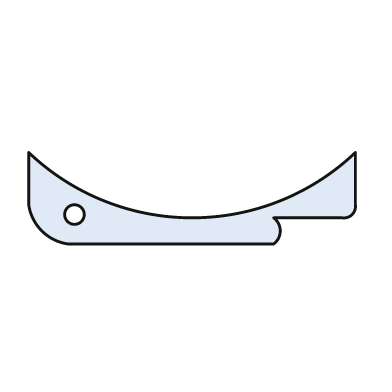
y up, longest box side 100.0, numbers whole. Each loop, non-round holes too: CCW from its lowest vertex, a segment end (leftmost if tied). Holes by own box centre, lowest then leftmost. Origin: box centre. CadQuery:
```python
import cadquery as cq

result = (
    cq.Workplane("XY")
    .moveTo(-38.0, -14.0)
    .lineTo(25.0, -14.0)
    .threePointArc((27.0, -10.0), (25.0, -6.0))
    .lineTo(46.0, -6.0)
    .threePointArc((49.0, -5.0), (50.0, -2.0))
    .lineTo(50.0, 14.0)
    .threePointArc((0.0, -6.0), (-50.0, 14.0))
    .lineTo(-50.0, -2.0)
    .threePointArc((-46.0, -10.0), (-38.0, -14.0))
    .close()
    .moveTo(-36.0, -5.0)
    .circle(3.0)
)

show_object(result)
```